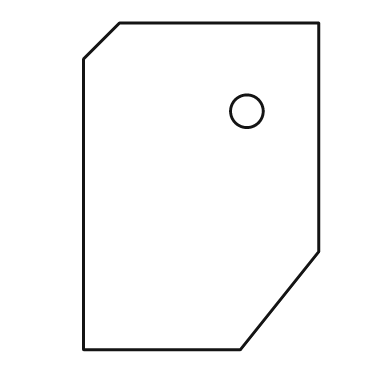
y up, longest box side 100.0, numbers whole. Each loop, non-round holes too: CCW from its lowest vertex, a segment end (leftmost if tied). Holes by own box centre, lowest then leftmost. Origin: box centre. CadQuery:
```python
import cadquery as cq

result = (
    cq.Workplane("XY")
    .moveTo(-36.0, -50.0)
    .lineTo(12.0, -50.0)
    .lineTo(36.0, -20.0)
    .lineTo(36.0, 50.0)
    .lineTo(-25.0, 50.0)
    .lineTo(-36.0, 39.0)
    .close()
    .moveTo(14.0, 23.0)
    .circle(5.0)
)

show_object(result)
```